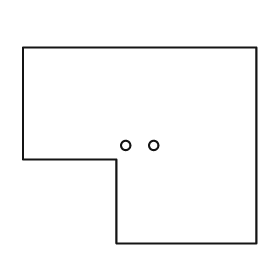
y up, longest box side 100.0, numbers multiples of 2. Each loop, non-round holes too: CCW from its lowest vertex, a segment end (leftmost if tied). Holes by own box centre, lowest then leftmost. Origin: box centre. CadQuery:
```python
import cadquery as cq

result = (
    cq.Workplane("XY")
    .moveTo(-10.0, -42.0)
    .lineTo(50.0, -42.0)
    .lineTo(50.0, 42.0)
    .lineTo(-50.0, 42.0)
    .lineTo(-50.0, -6.0)
    .lineTo(-10.0, -6.0)
    .close()
    .moveTo(-6.0, 0.0)
    .circle(2.0)
    .moveTo(6.0, 0.0)
    .circle(2.0)
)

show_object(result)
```